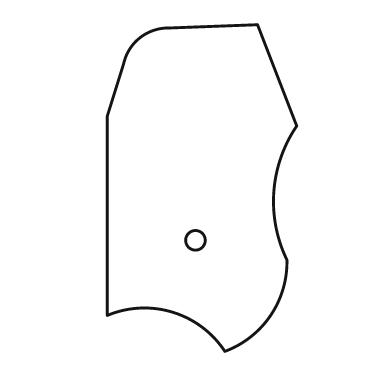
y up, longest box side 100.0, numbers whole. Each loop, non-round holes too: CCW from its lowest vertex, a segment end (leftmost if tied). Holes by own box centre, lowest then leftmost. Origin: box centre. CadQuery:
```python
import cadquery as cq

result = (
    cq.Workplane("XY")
    .moveTo(7.0, -50.0)
    .threePointArc((21.0, -39.0), (26.0, -22.0))
    .threePointArc((22.0, -1.0), (29.0, 19.0))
    .lineTo(17.0, 50.0)
    .lineTo(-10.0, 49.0)
    .threePointArc((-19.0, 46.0), (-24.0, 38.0))
    .lineTo(-29.0, 22.0)
    .lineTo(-29.0, -39.0)
    .threePointArc((-9.0, -38.0), (7.0, -50.0))
    .close()
    .moveTo(-2.0, -16.0)
    .circle(3.0)
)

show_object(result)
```